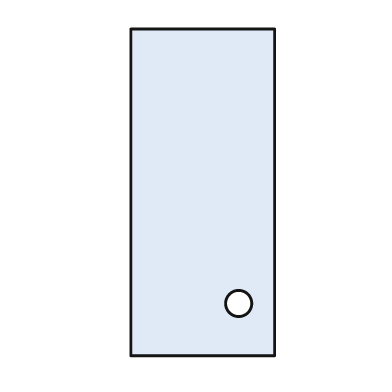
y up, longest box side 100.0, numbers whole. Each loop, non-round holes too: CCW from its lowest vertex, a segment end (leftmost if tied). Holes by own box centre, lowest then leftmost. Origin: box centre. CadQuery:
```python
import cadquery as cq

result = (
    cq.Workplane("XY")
    .moveTo(-22.0, -50.0)
    .lineTo(22.0, -50.0)
    .lineTo(22.0, 50.0)
    .lineTo(-22.0, 50.0)
    .close()
    .moveTo(11.0, -34.0)
    .circle(4.0)
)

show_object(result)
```